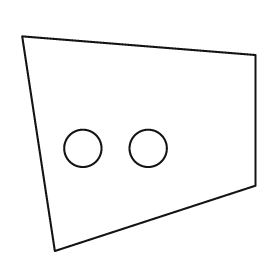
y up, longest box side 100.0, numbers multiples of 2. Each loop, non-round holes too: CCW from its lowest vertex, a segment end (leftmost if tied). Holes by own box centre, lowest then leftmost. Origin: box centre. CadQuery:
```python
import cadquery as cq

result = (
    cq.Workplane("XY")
    .moveTo(-36.0, -46.0)
    .lineTo(50.0, -18.0)
    .lineTo(50.0, 38.0)
    .lineTo(-50.0, 46.0)
    .close()
    .moveTo(-24.0, -2.0)
    .circle(8.0)
    .moveTo(4.0, -2.0)
    .circle(8.0)
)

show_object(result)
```